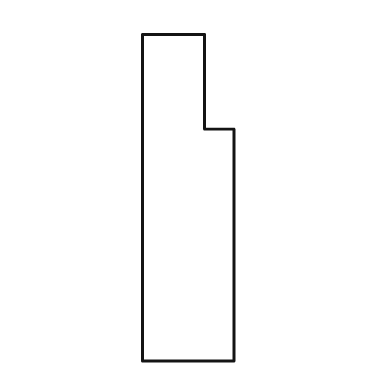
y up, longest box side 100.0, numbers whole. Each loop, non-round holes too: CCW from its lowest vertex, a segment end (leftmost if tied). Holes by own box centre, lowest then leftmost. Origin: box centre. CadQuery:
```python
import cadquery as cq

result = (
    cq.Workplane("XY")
    .moveTo(-14.0, -50.0)
    .lineTo(14.0, -50.0)
    .lineTo(14.0, 21.0)
    .lineTo(5.0, 21.0)
    .lineTo(5.0, 50.0)
    .lineTo(-14.0, 50.0)
    .close()
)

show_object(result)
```